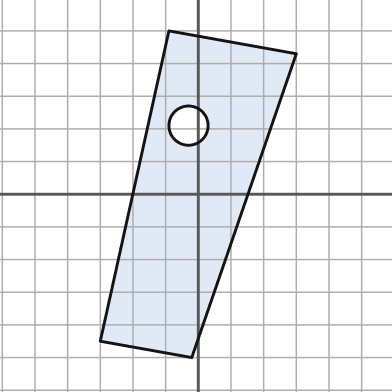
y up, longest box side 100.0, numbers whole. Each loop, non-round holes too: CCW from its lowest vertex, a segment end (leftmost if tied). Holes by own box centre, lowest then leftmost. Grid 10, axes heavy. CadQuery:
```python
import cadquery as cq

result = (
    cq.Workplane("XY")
    .moveTo(-2.0, -50.0)
    .lineTo(30.0, 43.0)
    .lineTo(-9.0, 50.0)
    .lineTo(-30.0, -45.0)
    .close()
    .moveTo(-3.0, 21.0)
    .circle(6.0)
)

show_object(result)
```